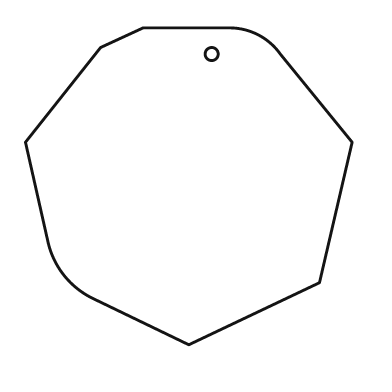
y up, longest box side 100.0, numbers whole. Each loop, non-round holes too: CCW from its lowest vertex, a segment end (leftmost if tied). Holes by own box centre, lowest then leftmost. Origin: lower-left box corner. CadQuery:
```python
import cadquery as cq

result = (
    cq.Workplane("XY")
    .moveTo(50.0, 0.0)
    .lineTo(90.0, 19.0)
    .lineTo(100.0, 62.0)
    .lineTo(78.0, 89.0)
    .threePointArc((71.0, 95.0), (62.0, 97.0))
    .lineTo(36.0, 97.0)
    .lineTo(23.0, 91.0)
    .lineTo(0.0, 62.0)
    .lineTo(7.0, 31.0)
    .threePointArc((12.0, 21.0), (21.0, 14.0))
    .close()
    .moveTo(57.0, 89.0)
    .circle(2.0)
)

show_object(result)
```